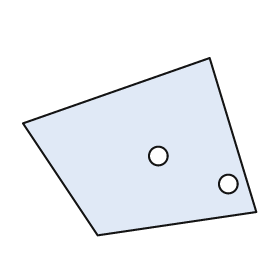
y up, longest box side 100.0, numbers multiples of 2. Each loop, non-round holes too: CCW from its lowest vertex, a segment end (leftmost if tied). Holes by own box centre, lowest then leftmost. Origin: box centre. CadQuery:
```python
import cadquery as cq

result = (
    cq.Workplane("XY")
    .moveTo(-18.0, -38.0)
    .lineTo(50.0, -28.0)
    .lineTo(30.0, 38.0)
    .lineTo(-50.0, 10.0)
    .close()
    .moveTo(38.0, -16.0)
    .circle(4.0)
    .moveTo(8.0, -4.0)
    .circle(4.0)
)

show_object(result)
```